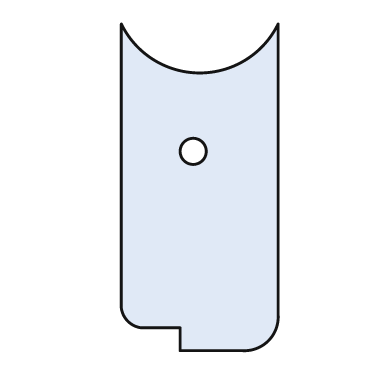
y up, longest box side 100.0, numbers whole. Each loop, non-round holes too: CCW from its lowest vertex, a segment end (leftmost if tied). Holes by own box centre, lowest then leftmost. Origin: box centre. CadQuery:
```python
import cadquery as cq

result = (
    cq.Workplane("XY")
    .moveTo(-6.0, -50.0)
    .lineTo(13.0, -50.0)
    .threePointArc((21.0, -47.0), (24.0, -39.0))
    .lineTo(24.0, 50.0)
    .threePointArc((0.0, 35.0), (-24.0, 50.0))
    .lineTo(-24.0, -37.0)
    .threePointArc((-22.0, -41.0), (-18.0, -43.0))
    .lineTo(-6.0, -43.0)
    .close()
    .moveTo(-2.0, 11.0)
    .circle(4.0)
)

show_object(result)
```